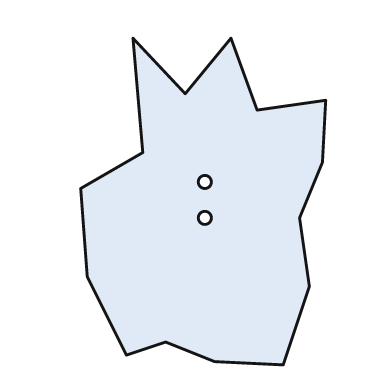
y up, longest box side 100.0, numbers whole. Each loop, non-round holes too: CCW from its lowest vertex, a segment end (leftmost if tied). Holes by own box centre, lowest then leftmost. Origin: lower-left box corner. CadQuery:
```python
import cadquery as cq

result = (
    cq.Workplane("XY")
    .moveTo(62.0, 0.0)
    .lineTo(70.0, 24.0)
    .lineTo(67.0, 45.0)
    .lineTo(74.0, 62.0)
    .lineTo(75.0, 81.0)
    .lineTo(54.0, 78.0)
    .lineTo(46.0, 100.0)
    .lineTo(32.0, 83.0)
    .lineTo(16.0, 100.0)
    .lineTo(19.0, 65.0)
    .lineTo(0.0, 54.0)
    .lineTo(2.0, 27.0)
    .lineTo(14.0, 3.0)
    .lineTo(26.0, 7.0)
    .lineTo(41.0, 1.0)
    .close()
    .moveTo(38.0, 45.0)
    .circle(2.0)
    .moveTo(38.0, 56.0)
    .circle(2.0)
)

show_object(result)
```